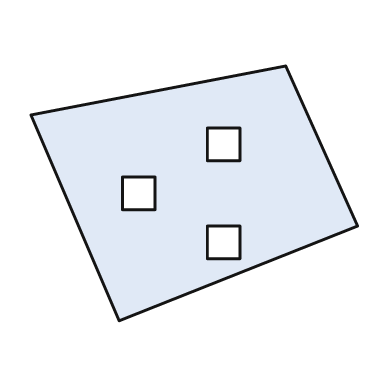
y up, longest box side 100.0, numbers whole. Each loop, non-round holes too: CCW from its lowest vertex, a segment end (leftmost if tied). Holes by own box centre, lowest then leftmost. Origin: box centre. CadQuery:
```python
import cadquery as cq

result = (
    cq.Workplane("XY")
    .moveTo(-23.0, -39.0)
    .lineTo(50.0, -10.0)
    .lineTo(28.0, 39.0)
    .lineTo(-50.0, 24.0)
    .close()
    .moveTo(4.0, -20.0)
    .lineTo(14.0, -20.0)
    .lineTo(14.0, -10.0)
    .lineTo(4.0, -10.0)
    .close()
    .moveTo(-22.0, -5.0)
    .lineTo(-12.0, -5.0)
    .lineTo(-12.0, 5.0)
    .lineTo(-22.0, 5.0)
    .close()
    .moveTo(4.0, 10.0)
    .lineTo(14.0, 10.0)
    .lineTo(14.0, 20.0)
    .lineTo(4.0, 20.0)
    .close()
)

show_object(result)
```